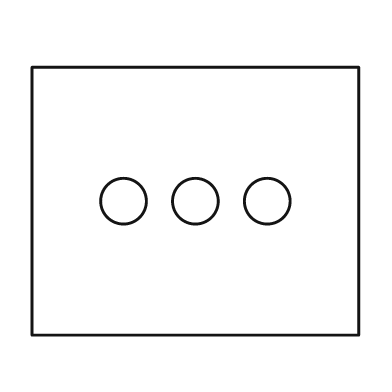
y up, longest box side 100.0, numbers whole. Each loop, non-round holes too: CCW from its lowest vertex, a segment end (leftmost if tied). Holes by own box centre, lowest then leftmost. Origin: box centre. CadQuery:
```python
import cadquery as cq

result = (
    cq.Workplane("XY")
    .moveTo(-50.0, -41.0)
    .lineTo(50.0, -41.0)
    .lineTo(50.0, 41.0)
    .lineTo(-50.0, 41.0)
    .close()
    .moveTo(-22.0, 0.0)
    .circle(7.0)
    .moveTo(0.0, 0.0)
    .circle(7.0)
    .moveTo(22.0, 0.0)
    .circle(7.0)
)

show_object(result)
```